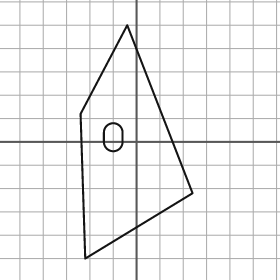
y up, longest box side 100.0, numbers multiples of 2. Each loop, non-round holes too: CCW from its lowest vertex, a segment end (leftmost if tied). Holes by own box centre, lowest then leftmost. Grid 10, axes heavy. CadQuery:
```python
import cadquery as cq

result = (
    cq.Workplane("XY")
    .moveTo(-22.0, -50.0)
    .lineTo(24.0, -22.0)
    .lineTo(-4.0, 50.0)
    .lineTo(-24.0, 12.0)
    .close()
    .moveTo(-14.0, 0.0)
    .threePointArc((-10.0, -4.0), (-6.0, 0.0))
    .lineTo(-6.0, 4.0)
    .threePointArc((-10.0, 8.0), (-14.0, 4.0))
    .close()
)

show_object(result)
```